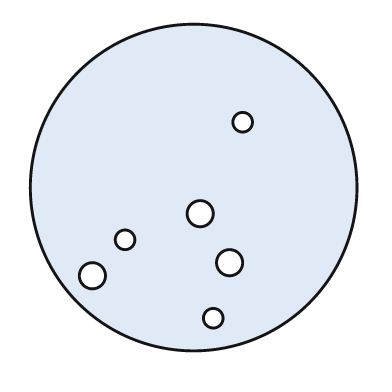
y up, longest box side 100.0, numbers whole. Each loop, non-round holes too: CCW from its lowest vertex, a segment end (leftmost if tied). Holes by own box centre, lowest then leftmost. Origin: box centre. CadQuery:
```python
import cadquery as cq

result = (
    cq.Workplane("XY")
    .moveTo(0.0, 0.0)
    .circle(50.0)
    .moveTo(6.0, -40.0)
    .circle(3.0)
    .moveTo(-31.0, -27.0)
    .circle(4.0)
    .moveTo(11.0, -23.0)
    .circle(4.0)
    .moveTo(-21.0, -16.0)
    .circle(3.0)
    .moveTo(2.0, -8.0)
    .circle(4.0)
    .moveTo(15.0, 20.0)
    .circle(3.0)
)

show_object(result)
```